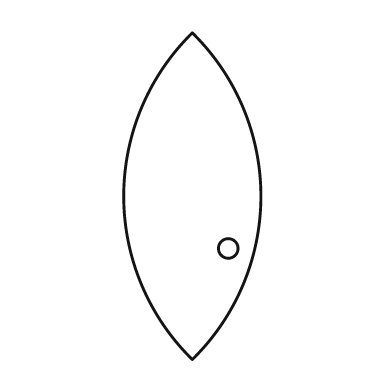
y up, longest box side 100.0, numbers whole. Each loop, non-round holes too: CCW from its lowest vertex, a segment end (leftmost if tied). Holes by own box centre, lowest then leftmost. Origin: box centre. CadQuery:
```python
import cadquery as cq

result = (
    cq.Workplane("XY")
    .moveTo(0.0, -50.0)
    .threePointArc((21.0, 0.0), (0.0, 50.0))
    .threePointArc((-21.0, 0.0), (0.0, -50.0))
    .close()
    .moveTo(11.0, -16.0)
    .circle(3.0)
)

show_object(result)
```